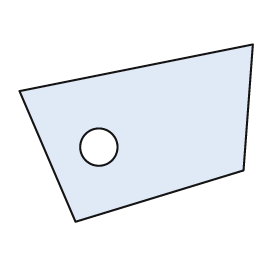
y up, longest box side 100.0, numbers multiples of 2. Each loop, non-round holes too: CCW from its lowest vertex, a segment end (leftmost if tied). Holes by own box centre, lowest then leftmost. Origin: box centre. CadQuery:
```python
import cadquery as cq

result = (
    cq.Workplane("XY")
    .moveTo(-26.0, -38.0)
    .lineTo(46.0, -16.0)
    .lineTo(50.0, 38.0)
    .lineTo(-50.0, 18.0)
    .close()
    .moveTo(-16.0, -6.0)
    .circle(8.0)
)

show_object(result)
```